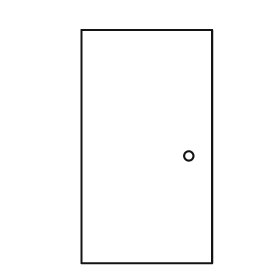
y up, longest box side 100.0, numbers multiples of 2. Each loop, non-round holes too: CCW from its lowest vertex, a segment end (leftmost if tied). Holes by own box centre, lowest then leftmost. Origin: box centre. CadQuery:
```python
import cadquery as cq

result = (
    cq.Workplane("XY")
    .moveTo(-28.0, -50.0)
    .lineTo(28.0, -50.0)
    .lineTo(28.0, 50.0)
    .lineTo(-28.0, 50.0)
    .close()
    .moveTo(18.0, -4.0)
    .circle(2.0)
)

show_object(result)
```